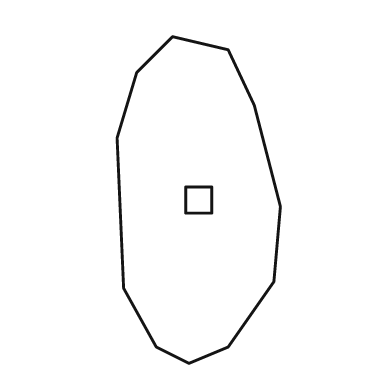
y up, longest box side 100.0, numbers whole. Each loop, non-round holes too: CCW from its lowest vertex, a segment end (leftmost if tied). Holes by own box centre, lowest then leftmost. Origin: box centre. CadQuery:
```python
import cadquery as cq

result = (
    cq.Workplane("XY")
    .moveTo(-3.0, -50.0)
    .lineTo(9.0, -45.0)
    .lineTo(23.0, -25.0)
    .lineTo(25.0, -2.0)
    .lineTo(17.0, 29.0)
    .lineTo(9.0, 46.0)
    .lineTo(-8.0, 50.0)
    .lineTo(-19.0, 39.0)
    .lineTo(-25.0, 19.0)
    .lineTo(-23.0, -27.0)
    .lineTo(-13.0, -45.0)
    .close()
    .moveTo(-4.0, -4.0)
    .lineTo(4.0, -4.0)
    .lineTo(4.0, 4.0)
    .lineTo(-4.0, 4.0)
    .close()
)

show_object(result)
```